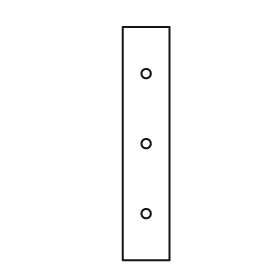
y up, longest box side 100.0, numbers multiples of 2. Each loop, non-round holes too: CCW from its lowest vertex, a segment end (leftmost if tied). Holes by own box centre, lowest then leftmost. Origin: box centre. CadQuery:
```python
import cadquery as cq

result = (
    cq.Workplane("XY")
    .moveTo(-10.0, -50.0)
    .lineTo(10.0, -50.0)
    .lineTo(10.0, 50.0)
    .lineTo(-10.0, 50.0)
    .close()
    .moveTo(0.0, -30.0)
    .circle(2.0)
    .moveTo(0.0, 0.0)
    .circle(2.0)
    .moveTo(0.0, 30.0)
    .circle(2.0)
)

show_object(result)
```